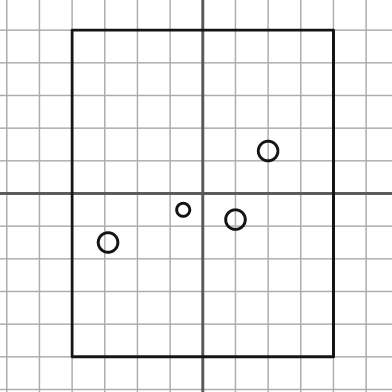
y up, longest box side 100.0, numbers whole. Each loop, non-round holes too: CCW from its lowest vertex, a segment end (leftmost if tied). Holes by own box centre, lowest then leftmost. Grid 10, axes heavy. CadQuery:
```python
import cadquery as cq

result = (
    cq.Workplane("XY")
    .moveTo(-40.0, -50.0)
    .lineTo(40.0, -50.0)
    .lineTo(40.0, 50.0)
    .lineTo(-40.0, 50.0)
    .close()
    .moveTo(-29.0, -15.0)
    .circle(3.0)
    .moveTo(10.0, -8.0)
    .circle(3.0)
    .moveTo(-6.0, -5.0)
    .circle(2.0)
    .moveTo(20.0, 13.0)
    .circle(3.0)
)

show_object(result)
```